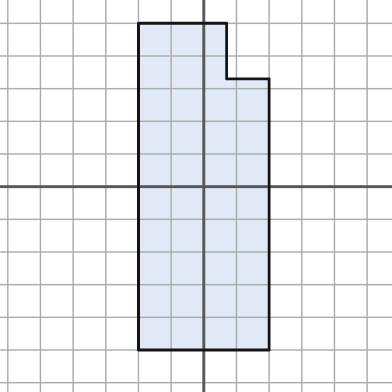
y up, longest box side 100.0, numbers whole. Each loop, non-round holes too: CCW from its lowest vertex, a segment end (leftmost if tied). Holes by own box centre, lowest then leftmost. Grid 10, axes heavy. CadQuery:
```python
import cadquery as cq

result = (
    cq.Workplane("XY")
    .moveTo(-20.0, -50.0)
    .lineTo(20.0, -50.0)
    .lineTo(20.0, 33.0)
    .lineTo(7.0, 33.0)
    .lineTo(7.0, 50.0)
    .lineTo(-20.0, 50.0)
    .close()
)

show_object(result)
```